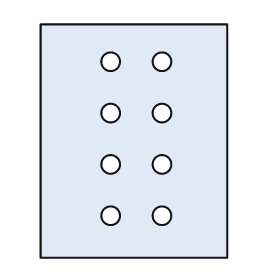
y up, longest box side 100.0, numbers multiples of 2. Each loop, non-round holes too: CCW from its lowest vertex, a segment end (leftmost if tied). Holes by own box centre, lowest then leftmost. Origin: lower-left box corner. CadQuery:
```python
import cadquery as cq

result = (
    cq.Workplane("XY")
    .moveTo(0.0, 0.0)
    .lineTo(80.0, 0.0)
    .lineTo(80.0, 100.0)
    .lineTo(0.0, 100.0)
    .close()
    .moveTo(30.0, 18.0)
    .circle(4.0)
    .moveTo(52.0, 18.0)
    .circle(4.0)
    .moveTo(30.0, 40.0)
    .circle(4.0)
    .moveTo(52.0, 40.0)
    .circle(4.0)
    .moveTo(30.0, 62.0)
    .circle(4.0)
    .moveTo(52.0, 62.0)
    .circle(4.0)
    .moveTo(30.0, 84.0)
    .circle(4.0)
    .moveTo(52.0, 84.0)
    .circle(4.0)
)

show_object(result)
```